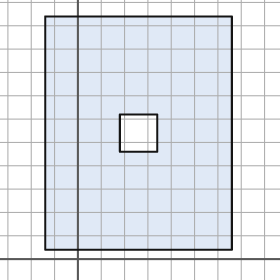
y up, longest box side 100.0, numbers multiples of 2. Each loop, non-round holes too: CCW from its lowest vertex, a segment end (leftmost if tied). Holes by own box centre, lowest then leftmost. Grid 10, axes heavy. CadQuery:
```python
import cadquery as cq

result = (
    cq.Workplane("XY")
    .moveTo(-14.0, 4.0)
    .lineTo(66.0, 4.0)
    .lineTo(66.0, 104.0)
    .lineTo(-14.0, 104.0)
    .close()
    .moveTo(18.0, 46.0)
    .lineTo(34.0, 46.0)
    .lineTo(34.0, 62.0)
    .lineTo(18.0, 62.0)
    .close()
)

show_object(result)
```